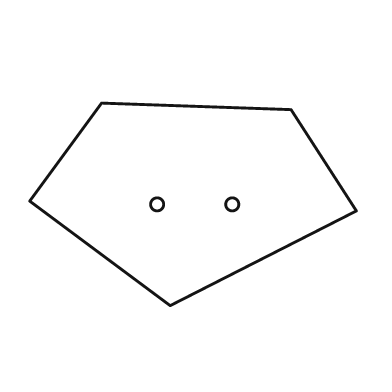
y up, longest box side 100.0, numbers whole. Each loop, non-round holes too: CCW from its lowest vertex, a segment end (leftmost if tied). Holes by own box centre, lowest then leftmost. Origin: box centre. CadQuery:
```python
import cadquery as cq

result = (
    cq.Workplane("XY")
    .moveTo(-7.0, -31.0)
    .lineTo(50.0, -2.0)
    .lineTo(30.0, 29.0)
    .lineTo(-28.0, 31.0)
    .lineTo(-50.0, 1.0)
    .close()
    .moveTo(-11.0, 0.0)
    .circle(2.0)
    .moveTo(12.0, 0.0)
    .circle(2.0)
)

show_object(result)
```